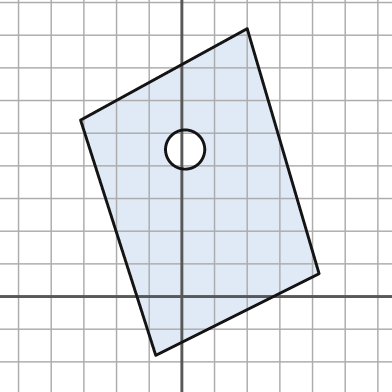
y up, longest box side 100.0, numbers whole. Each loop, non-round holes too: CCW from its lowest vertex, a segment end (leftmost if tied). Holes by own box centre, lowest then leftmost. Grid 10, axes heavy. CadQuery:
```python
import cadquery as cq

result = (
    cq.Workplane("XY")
    .moveTo(-8.0, -18.0)
    .lineTo(42.0, 7.0)
    .lineTo(20.0, 82.0)
    .lineTo(-31.0, 54.0)
    .close()
    .moveTo(1.0, 45.0)
    .circle(6.0)
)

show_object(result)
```